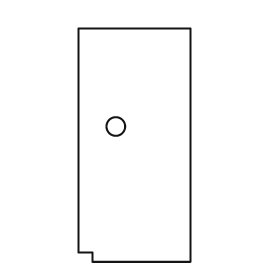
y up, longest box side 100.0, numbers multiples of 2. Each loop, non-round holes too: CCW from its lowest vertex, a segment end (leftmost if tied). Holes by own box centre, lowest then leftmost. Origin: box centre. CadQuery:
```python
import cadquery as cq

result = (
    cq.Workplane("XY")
    .moveTo(-18.0, -50.0)
    .lineTo(24.0, -50.0)
    .lineTo(24.0, 50.0)
    .lineTo(-24.0, 50.0)
    .lineTo(-24.0, -46.0)
    .lineTo(-18.0, -46.0)
    .close()
    .moveTo(-8.0, 8.0)
    .circle(4.0)
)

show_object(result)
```